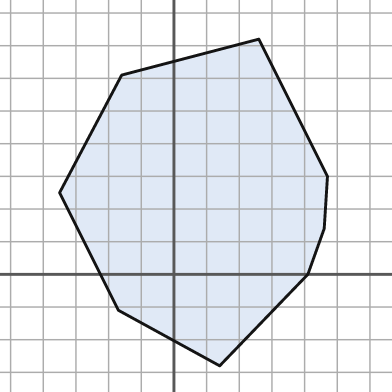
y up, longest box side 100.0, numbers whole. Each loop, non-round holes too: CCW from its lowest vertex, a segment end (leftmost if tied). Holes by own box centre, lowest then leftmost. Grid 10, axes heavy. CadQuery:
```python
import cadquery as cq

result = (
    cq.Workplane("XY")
    .moveTo(14.0, -28.0)
    .lineTo(41.0, 0.0)
    .lineTo(46.0, 14.0)
    .lineTo(47.0, 30.0)
    .lineTo(26.0, 72.0)
    .lineTo(-16.0, 61.0)
    .lineTo(-35.0, 25.0)
    .lineTo(-17.0, -11.0)
    .close()
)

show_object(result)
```